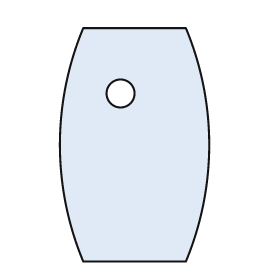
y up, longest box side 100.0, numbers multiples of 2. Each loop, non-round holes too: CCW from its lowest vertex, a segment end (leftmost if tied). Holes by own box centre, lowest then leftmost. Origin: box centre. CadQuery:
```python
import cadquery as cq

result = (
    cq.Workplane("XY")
    .moveTo(-22.0, -50.0)
    .lineTo(22.0, -50.0)
    .threePointArc((32.0, 0.0), (22.0, 50.0))
    .lineTo(-22.0, 50.0)
    .threePointArc((-32.0, 0.0), (-22.0, -50.0))
    .close()
    .moveTo(-6.0, 22.0)
    .circle(6.0)
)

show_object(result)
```